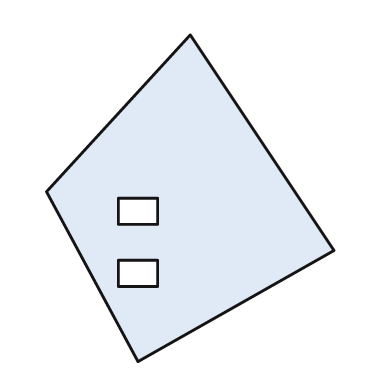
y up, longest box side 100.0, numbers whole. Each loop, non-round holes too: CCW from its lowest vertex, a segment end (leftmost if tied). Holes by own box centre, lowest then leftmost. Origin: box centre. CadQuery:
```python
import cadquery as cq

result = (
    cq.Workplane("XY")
    .moveTo(-16.0, -50.0)
    .lineTo(44.0, -16.0)
    .lineTo(0.0, 50.0)
    .lineTo(-44.0, 2.0)
    .close()
    .moveTo(-22.0, -27.0)
    .lineTo(-10.0, -27.0)
    .lineTo(-10.0, -19.0)
    .lineTo(-22.0, -19.0)
    .close()
    .moveTo(-22.0, -8.0)
    .lineTo(-10.0, -8.0)
    .lineTo(-10.0, 0.0)
    .lineTo(-22.0, 0.0)
    .close()
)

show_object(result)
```